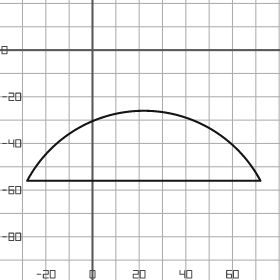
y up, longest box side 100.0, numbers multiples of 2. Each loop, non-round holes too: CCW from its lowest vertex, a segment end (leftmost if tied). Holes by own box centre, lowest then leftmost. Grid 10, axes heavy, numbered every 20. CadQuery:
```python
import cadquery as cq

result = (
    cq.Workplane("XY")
    .moveTo(-28.0, -56.0)
    .lineTo(72.0, -56.0)
    .threePointArc((22.0, -26.0), (-28.0, -56.0))
    .close()
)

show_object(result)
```